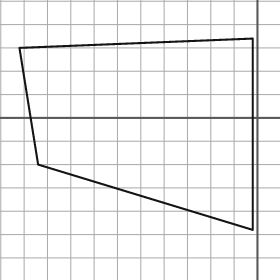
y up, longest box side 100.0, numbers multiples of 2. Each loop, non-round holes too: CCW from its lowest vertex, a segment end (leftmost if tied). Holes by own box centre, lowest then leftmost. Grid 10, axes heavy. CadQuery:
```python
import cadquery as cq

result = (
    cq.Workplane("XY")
    .moveTo(-2.0, -48.0)
    .lineTo(-2.0, 34.0)
    .lineTo(-102.0, 30.0)
    .lineTo(-94.0, -20.0)
    .close()
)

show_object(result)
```